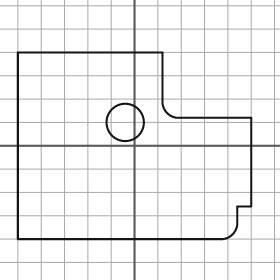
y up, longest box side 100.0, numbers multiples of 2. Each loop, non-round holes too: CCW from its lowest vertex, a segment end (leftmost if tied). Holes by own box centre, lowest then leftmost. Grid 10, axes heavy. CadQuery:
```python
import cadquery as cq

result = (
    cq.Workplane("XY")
    .moveTo(-50.0, -40.0)
    .lineTo(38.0, -40.0)
    .threePointArc((42.0, -38.0), (44.0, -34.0))
    .lineTo(44.0, -26.0)
    .lineTo(50.0, -26.0)
    .lineTo(50.0, 12.0)
    .lineTo(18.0, 12.0)
    .threePointArc((14.0, 14.0), (12.0, 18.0))
    .lineTo(12.0, 40.0)
    .lineTo(-50.0, 40.0)
    .close()
    .moveTo(-4.0, 10.0)
    .circle(8.0)
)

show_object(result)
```